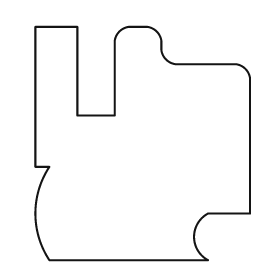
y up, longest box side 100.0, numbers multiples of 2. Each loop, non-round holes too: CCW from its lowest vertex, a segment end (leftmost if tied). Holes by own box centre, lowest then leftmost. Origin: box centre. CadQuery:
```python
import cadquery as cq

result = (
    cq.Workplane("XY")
    .moveTo(-40.0, -50.0)
    .lineTo(28.0, -50.0)
    .threePointArc((22.0, -40.0), (28.0, -30.0))
    .lineTo(46.0, -30.0)
    .lineTo(46.0, 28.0)
    .threePointArc((44.0, 32.0), (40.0, 34.0))
    .lineTo(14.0, 34.0)
    .threePointArc((10.0, 36.0), (8.0, 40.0))
    .lineTo(8.0, 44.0)
    .threePointArc((6.0, 48.0), (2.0, 50.0))
    .lineTo(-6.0, 50.0)
    .threePointArc((-10.0, 48.0), (-12.0, 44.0))
    .lineTo(-12.0, 12.0)
    .lineTo(-28.0, 12.0)
    .lineTo(-28.0, 50.0)
    .lineTo(-46.0, 50.0)
    .lineTo(-46.0, -10.0)
    .lineTo(-40.0, -10.0)
    .threePointArc((-46.0, -30.0), (-40.0, -50.0))
    .close()
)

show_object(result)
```